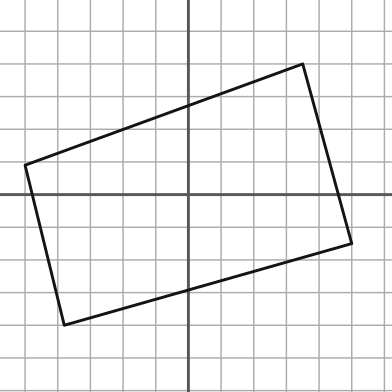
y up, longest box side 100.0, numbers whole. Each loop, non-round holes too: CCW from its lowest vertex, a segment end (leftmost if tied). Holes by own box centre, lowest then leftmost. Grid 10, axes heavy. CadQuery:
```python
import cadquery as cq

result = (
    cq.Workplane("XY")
    .moveTo(-38.0, -40.0)
    .lineTo(50.0, -15.0)
    .lineTo(35.0, 40.0)
    .lineTo(-50.0, 9.0)
    .close()
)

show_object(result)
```